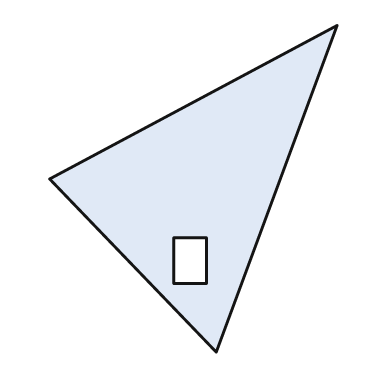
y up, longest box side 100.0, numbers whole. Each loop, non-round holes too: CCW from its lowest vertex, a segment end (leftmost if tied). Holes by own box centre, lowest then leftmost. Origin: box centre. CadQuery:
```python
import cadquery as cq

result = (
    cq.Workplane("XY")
    .moveTo(7.0, -50.0)
    .lineTo(44.0, 50.0)
    .lineTo(-44.0, 3.0)
    .close()
    .moveTo(-6.0, -29.0)
    .lineTo(4.0, -29.0)
    .lineTo(4.0, -15.0)
    .lineTo(-6.0, -15.0)
    .close()
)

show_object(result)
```